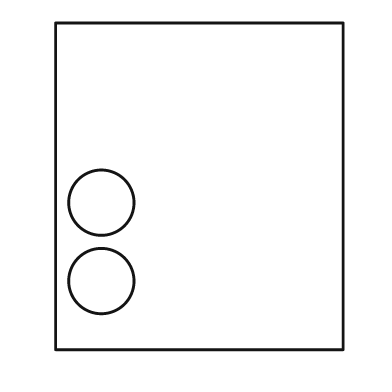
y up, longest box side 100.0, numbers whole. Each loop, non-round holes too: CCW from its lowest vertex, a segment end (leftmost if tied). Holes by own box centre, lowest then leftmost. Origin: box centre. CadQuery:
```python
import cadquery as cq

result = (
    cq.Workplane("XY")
    .moveTo(-44.0, -50.0)
    .lineTo(44.0, -50.0)
    .lineTo(44.0, 50.0)
    .lineTo(-44.0, 50.0)
    .close()
    .moveTo(-30.0, -29.0)
    .circle(10.0)
    .moveTo(-30.0, -5.0)
    .circle(10.0)
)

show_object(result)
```